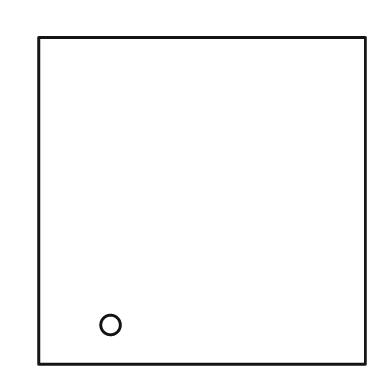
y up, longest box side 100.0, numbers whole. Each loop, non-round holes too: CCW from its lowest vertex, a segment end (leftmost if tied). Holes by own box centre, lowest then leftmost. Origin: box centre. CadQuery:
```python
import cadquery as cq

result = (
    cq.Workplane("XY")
    .moveTo(-50.0, -50.0)
    .lineTo(50.0, -50.0)
    .lineTo(50.0, 50.0)
    .lineTo(-50.0, 50.0)
    .close()
    .moveTo(-28.0, -38.0)
    .circle(3.0)
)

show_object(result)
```